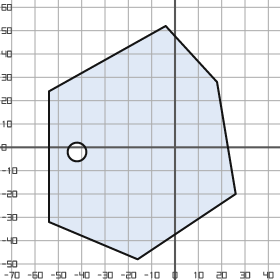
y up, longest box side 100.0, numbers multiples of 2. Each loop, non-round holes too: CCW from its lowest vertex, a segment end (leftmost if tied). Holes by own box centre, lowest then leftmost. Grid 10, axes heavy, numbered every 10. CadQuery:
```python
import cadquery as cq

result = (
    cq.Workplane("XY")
    .moveTo(-16.0, -48.0)
    .lineTo(26.0, -20.0)
    .lineTo(18.0, 28.0)
    .lineTo(-4.0, 52.0)
    .lineTo(-54.0, 24.0)
    .lineTo(-54.0, -32.0)
    .close()
    .moveTo(-42.0, -2.0)
    .circle(4.0)
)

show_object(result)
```